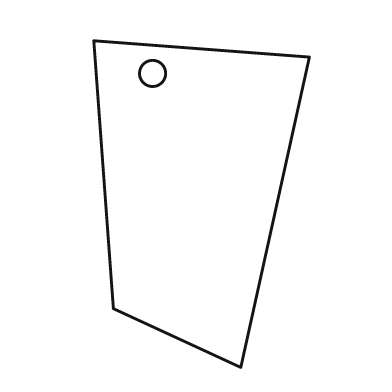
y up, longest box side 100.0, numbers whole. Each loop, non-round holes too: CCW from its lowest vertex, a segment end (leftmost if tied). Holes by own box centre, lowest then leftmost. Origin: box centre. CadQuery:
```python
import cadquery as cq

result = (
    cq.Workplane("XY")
    .moveTo(12.0, -50.0)
    .lineTo(33.0, 45.0)
    .lineTo(-33.0, 50.0)
    .lineTo(-27.0, -32.0)
    .close()
    .moveTo(-15.0, 40.0)
    .circle(4.0)
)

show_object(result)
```